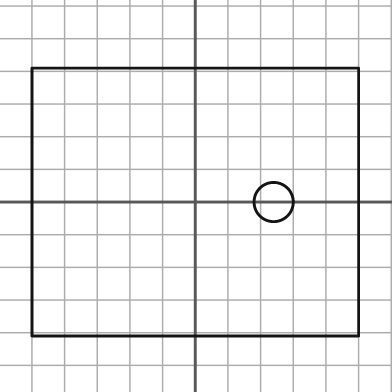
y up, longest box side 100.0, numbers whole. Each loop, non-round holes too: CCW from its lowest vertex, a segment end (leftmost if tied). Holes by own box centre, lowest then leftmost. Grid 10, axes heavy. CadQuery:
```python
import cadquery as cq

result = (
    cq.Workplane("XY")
    .moveTo(-50.0, -41.0)
    .lineTo(50.0, -41.0)
    .lineTo(50.0, 41.0)
    .lineTo(-50.0, 41.0)
    .close()
    .moveTo(24.0, 0.0)
    .circle(6.0)
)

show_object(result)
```